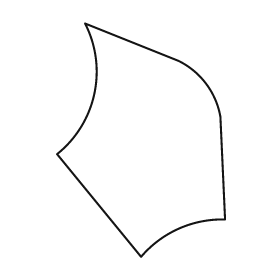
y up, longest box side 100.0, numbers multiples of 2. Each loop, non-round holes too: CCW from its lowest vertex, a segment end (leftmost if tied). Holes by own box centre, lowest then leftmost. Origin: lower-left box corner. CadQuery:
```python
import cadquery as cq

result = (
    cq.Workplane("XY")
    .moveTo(36.0, 0.0)
    .threePointArc((52.0, 12.0), (72.0, 16.0))
    .lineTo(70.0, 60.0)
    .threePointArc((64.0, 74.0), (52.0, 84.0))
    .lineTo(12.0, 100.0)
    .threePointArc((16.0, 70.0), (0.0, 44.0))
    .close()
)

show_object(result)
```